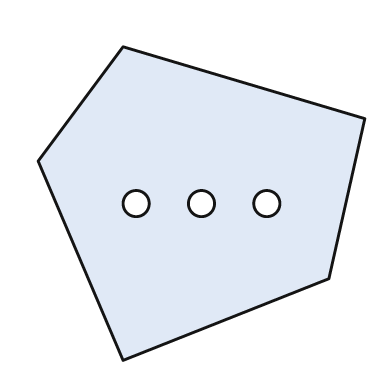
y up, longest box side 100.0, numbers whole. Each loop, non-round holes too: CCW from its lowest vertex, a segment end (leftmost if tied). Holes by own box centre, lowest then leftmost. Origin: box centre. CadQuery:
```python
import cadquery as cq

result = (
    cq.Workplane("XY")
    .moveTo(-24.0, -48.0)
    .lineTo(39.0, -23.0)
    .lineTo(50.0, 26.0)
    .lineTo(-24.0, 48.0)
    .lineTo(-50.0, 13.0)
    .close()
    .moveTo(-20.0, 0.0)
    .circle(4.0)
    .moveTo(0.0, 0.0)
    .circle(4.0)
    .moveTo(20.0, 0.0)
    .circle(4.0)
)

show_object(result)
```